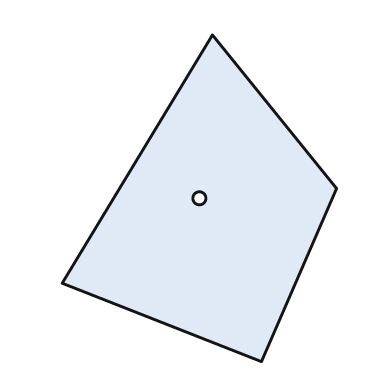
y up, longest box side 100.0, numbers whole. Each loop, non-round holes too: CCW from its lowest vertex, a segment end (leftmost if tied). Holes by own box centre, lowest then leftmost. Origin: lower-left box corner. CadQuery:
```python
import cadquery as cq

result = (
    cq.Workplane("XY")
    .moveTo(61.0, 0.0)
    .lineTo(84.0, 53.0)
    .lineTo(46.0, 100.0)
    .lineTo(0.0, 24.0)
    .close()
    .moveTo(42.0, 50.0)
    .circle(2.0)
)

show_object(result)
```